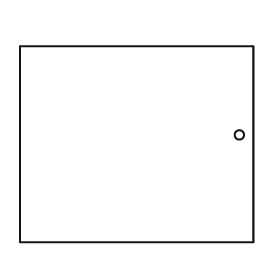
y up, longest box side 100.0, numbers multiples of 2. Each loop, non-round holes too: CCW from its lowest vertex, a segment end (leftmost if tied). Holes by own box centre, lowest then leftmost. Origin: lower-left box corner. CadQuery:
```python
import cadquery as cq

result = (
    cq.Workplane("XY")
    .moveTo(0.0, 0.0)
    .lineTo(100.0, 0.0)
    .lineTo(100.0, 84.0)
    .lineTo(0.0, 84.0)
    .close()
    .moveTo(94.0, 46.0)
    .circle(2.0)
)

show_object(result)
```